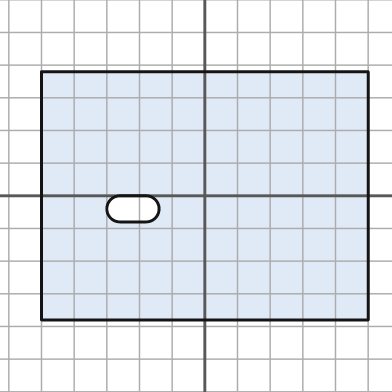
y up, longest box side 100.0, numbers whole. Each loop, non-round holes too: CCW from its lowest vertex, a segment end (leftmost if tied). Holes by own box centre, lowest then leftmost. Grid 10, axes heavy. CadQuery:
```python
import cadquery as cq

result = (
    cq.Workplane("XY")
    .moveTo(-50.0, -38.0)
    .lineTo(50.0, -38.0)
    .lineTo(50.0, 38.0)
    .lineTo(-50.0, 38.0)
    .close()
    .moveTo(-26.0, -8.0)
    .lineTo(-18.0, -8.0)
    .threePointArc((-14.0, -4.0), (-18.0, 0.0))
    .lineTo(-26.0, 0.0)
    .threePointArc((-30.0, -4.0), (-26.0, -8.0))
    .close()
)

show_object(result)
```